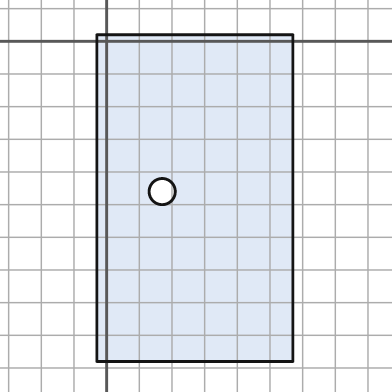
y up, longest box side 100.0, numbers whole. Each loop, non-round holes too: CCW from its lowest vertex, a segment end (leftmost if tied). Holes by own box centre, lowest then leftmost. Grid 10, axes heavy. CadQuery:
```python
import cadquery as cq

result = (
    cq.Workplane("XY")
    .moveTo(-3.0, -98.0)
    .lineTo(57.0, -98.0)
    .lineTo(57.0, 2.0)
    .lineTo(-3.0, 2.0)
    .close()
    .moveTo(17.0, -46.0)
    .circle(4.0)
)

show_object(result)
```